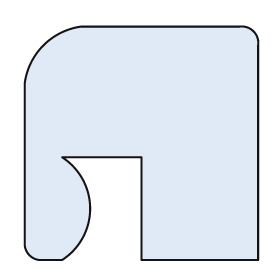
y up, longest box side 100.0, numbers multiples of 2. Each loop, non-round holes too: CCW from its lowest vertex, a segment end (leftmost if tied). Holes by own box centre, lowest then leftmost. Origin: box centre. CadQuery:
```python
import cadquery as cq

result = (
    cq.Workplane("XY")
    .moveTo(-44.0, -50.0)
    .lineTo(-34.0, -50.0)
    .threePointArc((-22.0, -28.0), (-34.0, -6.0))
    .lineTo(0.0, -6.0)
    .lineTo(0.0, -50.0)
    .lineTo(50.0, -50.0)
    .lineTo(50.0, 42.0)
    .threePointArc((48.0, 48.0), (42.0, 50.0))
    .lineTo(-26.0, 50.0)
    .threePointArc((-42.0, 42.0), (-50.0, 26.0))
    .lineTo(-50.0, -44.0)
    .threePointArc((-48.0, -48.0), (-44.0, -50.0))
    .close()
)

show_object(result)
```